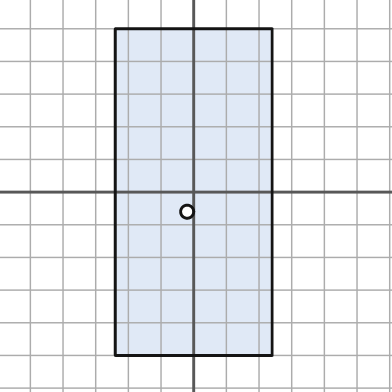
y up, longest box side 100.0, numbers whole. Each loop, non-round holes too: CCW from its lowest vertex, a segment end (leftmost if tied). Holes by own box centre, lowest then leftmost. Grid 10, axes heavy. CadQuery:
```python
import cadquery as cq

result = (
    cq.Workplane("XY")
    .moveTo(-24.0, -50.0)
    .lineTo(24.0, -50.0)
    .lineTo(24.0, 50.0)
    .lineTo(-24.0, 50.0)
    .close()
    .moveTo(-2.0, -6.0)
    .circle(2.0)
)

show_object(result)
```